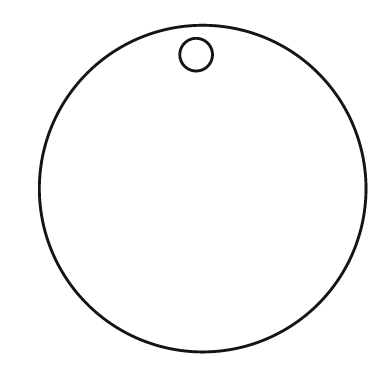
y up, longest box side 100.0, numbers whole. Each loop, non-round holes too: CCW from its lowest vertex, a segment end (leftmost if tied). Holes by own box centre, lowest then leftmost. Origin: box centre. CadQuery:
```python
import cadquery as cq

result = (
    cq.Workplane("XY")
    .moveTo(0.0, 0.0)
    .circle(50.0)
    .moveTo(-2.0, 41.0)
    .circle(5.0)
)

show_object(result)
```